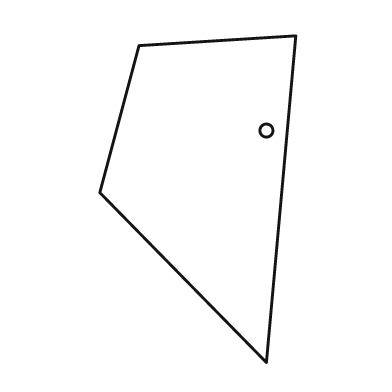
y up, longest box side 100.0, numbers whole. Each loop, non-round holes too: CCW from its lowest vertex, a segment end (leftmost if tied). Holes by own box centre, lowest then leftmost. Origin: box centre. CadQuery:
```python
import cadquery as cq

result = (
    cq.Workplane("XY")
    .moveTo(21.0, -50.0)
    .lineTo(30.0, 50.0)
    .lineTo(-18.0, 47.0)
    .lineTo(-30.0, 2.0)
    .close()
    .moveTo(21.0, 21.0)
    .circle(2.0)
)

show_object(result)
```